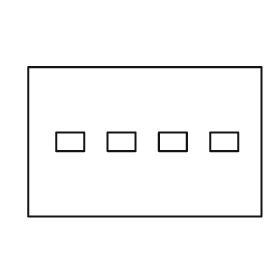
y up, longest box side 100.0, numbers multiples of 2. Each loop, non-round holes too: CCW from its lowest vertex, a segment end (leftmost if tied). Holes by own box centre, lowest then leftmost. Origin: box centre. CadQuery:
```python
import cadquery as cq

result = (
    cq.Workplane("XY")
    .moveTo(-50.0, -32.0)
    .lineTo(50.0, -32.0)
    .lineTo(50.0, 32.0)
    .lineTo(-50.0, 32.0)
    .close()
    .moveTo(-38.0, -4.0)
    .lineTo(-26.0, -4.0)
    .lineTo(-26.0, 4.0)
    .lineTo(-38.0, 4.0)
    .close()
    .moveTo(-16.0, -4.0)
    .lineTo(-4.0, -4.0)
    .lineTo(-4.0, 4.0)
    .lineTo(-16.0, 4.0)
    .close()
    .moveTo(6.0, -4.0)
    .lineTo(18.0, -4.0)
    .lineTo(18.0, 4.0)
    .lineTo(6.0, 4.0)
    .close()
    .moveTo(28.0, -4.0)
    .lineTo(40.0, -4.0)
    .lineTo(40.0, 4.0)
    .lineTo(28.0, 4.0)
    .close()
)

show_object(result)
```